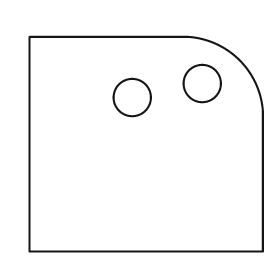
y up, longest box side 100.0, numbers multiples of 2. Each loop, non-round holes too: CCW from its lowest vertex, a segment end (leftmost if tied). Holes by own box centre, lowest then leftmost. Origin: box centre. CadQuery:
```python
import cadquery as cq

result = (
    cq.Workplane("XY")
    .moveTo(-50.0, -46.0)
    .lineTo(50.0, -46.0)
    .lineTo(50.0, 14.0)
    .threePointArc((40.0, 36.0), (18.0, 46.0))
    .lineTo(-50.0, 46.0)
    .close()
    .moveTo(-6.0, 20.0)
    .circle(8.0)
    .moveTo(24.0, 26.0)
    .circle(8.0)
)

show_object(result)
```